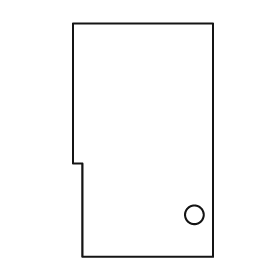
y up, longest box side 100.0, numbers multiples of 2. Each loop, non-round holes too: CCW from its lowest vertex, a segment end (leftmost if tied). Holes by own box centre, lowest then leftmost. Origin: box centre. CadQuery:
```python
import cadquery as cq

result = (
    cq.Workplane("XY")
    .moveTo(-26.0, -50.0)
    .lineTo(30.0, -50.0)
    .lineTo(30.0, 50.0)
    .lineTo(-30.0, 50.0)
    .lineTo(-30.0, -10.0)
    .lineTo(-26.0, -10.0)
    .close()
    .moveTo(22.0, -32.0)
    .circle(4.0)
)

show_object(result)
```